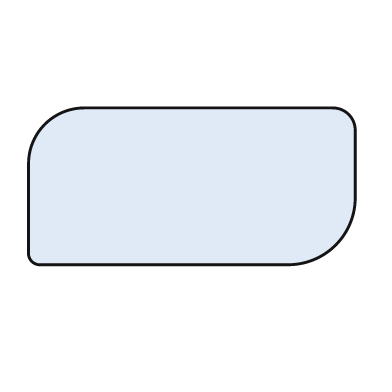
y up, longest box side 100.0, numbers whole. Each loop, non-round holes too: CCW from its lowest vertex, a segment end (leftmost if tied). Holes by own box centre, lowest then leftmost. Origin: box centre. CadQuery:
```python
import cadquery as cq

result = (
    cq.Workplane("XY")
    .moveTo(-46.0, -24.0)
    .lineTo(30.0, -24.0)
    .threePointArc((44.0, -18.0), (50.0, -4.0))
    .lineTo(50.0, 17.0)
    .threePointArc((48.0, 22.0), (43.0, 24.0))
    .lineTo(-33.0, 24.0)
    .threePointArc((-45.0, 19.0), (-50.0, 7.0))
    .lineTo(-50.0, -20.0)
    .threePointArc((-49.0, -23.0), (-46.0, -24.0))
    .close()
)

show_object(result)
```